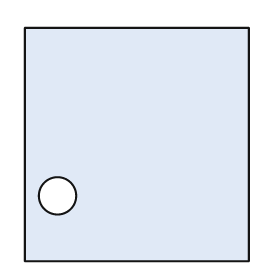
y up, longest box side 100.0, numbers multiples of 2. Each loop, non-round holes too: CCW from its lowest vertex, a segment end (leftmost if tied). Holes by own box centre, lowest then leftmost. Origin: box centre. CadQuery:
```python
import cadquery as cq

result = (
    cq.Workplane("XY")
    .moveTo(-48.0, -50.0)
    .lineTo(48.0, -50.0)
    .lineTo(48.0, 50.0)
    .lineTo(-48.0, 50.0)
    .close()
    .moveTo(-34.0, -22.0)
    .circle(8.0)
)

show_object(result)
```